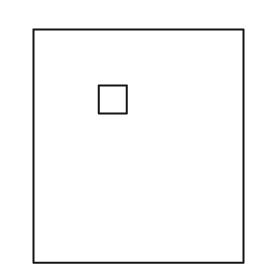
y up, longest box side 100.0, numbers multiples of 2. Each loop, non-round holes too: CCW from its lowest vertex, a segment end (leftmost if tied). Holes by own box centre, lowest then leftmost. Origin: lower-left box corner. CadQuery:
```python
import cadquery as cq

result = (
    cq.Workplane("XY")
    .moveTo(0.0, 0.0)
    .lineTo(90.0, 0.0)
    .lineTo(90.0, 100.0)
    .lineTo(0.0, 100.0)
    .close()
    .moveTo(28.0, 64.0)
    .lineTo(40.0, 64.0)
    .lineTo(40.0, 76.0)
    .lineTo(28.0, 76.0)
    .close()
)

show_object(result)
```